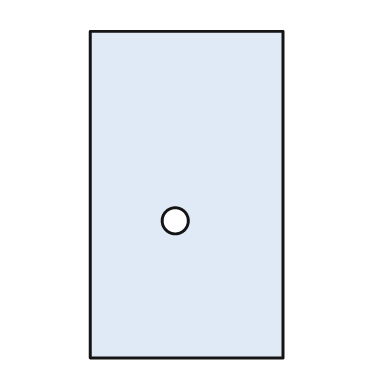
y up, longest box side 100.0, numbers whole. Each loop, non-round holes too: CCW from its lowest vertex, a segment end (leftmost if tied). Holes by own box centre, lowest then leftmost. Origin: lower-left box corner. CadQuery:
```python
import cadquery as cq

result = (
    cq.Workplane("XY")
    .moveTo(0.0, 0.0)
    .lineTo(59.0, 0.0)
    .lineTo(59.0, 100.0)
    .lineTo(0.0, 100.0)
    .close()
    .moveTo(26.0, 42.0)
    .circle(4.0)
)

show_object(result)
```